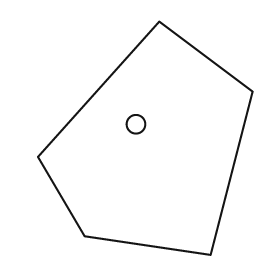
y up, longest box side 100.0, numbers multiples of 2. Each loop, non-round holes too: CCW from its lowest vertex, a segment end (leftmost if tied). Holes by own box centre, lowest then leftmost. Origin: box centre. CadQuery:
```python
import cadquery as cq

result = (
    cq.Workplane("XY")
    .moveTo(28.0, -50.0)
    .lineTo(46.0, 20.0)
    .lineTo(6.0, 50.0)
    .lineTo(-46.0, -8.0)
    .lineTo(-26.0, -42.0)
    .close()
    .moveTo(-4.0, 6.0)
    .circle(4.0)
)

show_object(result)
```